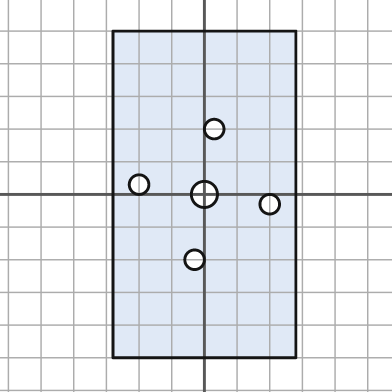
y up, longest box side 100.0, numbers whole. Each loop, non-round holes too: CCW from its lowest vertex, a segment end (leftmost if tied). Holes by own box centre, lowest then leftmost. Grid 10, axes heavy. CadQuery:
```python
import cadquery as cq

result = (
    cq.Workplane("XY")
    .moveTo(-28.0, -50.0)
    .lineTo(28.0, -50.0)
    .lineTo(28.0, 50.0)
    .lineTo(-28.0, 50.0)
    .close()
    .moveTo(-3.0, -20.0)
    .circle(3.0)
    .moveTo(20.0, -3.0)
    .circle(3.0)
    .moveTo(0.0, 0.0)
    .circle(4.0)
    .moveTo(-20.0, 3.0)
    .circle(3.0)
    .moveTo(3.0, 20.0)
    .circle(3.0)
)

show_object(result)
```